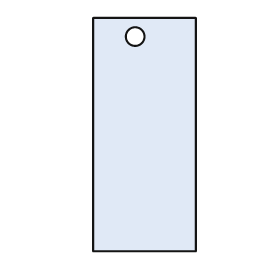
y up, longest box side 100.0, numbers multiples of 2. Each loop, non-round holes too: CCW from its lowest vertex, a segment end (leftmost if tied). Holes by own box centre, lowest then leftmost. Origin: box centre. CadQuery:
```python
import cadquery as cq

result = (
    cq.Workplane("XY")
    .moveTo(-22.0, -50.0)
    .lineTo(22.0, -50.0)
    .lineTo(22.0, 50.0)
    .lineTo(-22.0, 50.0)
    .close()
    .moveTo(-4.0, 42.0)
    .circle(4.0)
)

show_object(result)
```